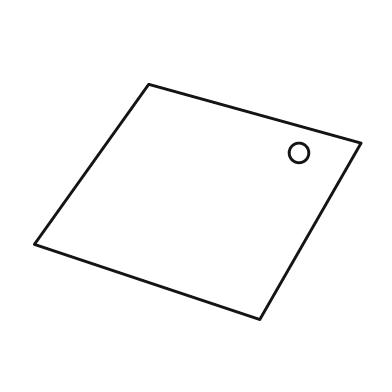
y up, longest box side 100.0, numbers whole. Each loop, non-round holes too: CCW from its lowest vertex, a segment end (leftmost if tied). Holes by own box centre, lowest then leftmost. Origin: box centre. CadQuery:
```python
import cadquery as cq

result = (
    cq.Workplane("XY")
    .moveTo(19.0, -36.0)
    .lineTo(50.0, 18.0)
    .lineTo(-15.0, 36.0)
    .lineTo(-50.0, -13.0)
    .close()
    .moveTo(31.0, 15.0)
    .circle(3.0)
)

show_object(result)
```